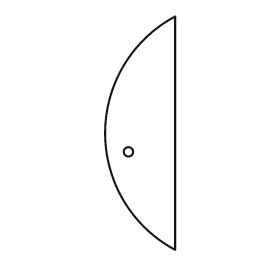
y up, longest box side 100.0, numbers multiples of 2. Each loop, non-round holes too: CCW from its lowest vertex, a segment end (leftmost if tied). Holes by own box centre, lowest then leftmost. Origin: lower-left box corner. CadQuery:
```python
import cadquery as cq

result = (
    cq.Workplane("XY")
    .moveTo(30.0, 0.0)
    .lineTo(30.0, 100.0)
    .threePointArc((0.0, 50.0), (30.0, 0.0))
    .close()
    .moveTo(10.0, 42.0)
    .circle(2.0)
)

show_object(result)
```